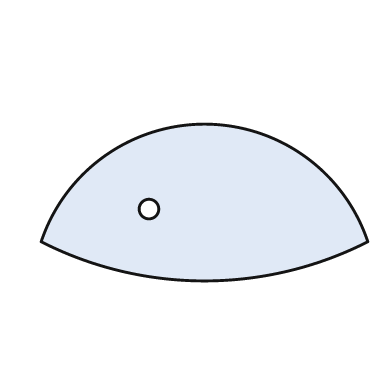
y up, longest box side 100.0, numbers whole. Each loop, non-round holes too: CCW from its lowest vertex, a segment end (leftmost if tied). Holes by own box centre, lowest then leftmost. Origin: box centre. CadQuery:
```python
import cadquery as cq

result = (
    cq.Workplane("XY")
    .moveTo(-50.0, -12.0)
    .threePointArc((0.0, -24.0), (50.0, -12.0))
    .threePointArc((0.0, 24.0), (-50.0, -12.0))
    .close()
    .moveTo(-17.0, -2.0)
    .circle(3.0)
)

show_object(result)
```